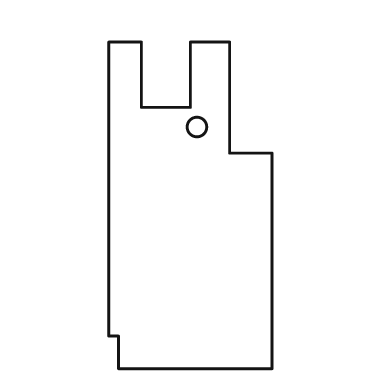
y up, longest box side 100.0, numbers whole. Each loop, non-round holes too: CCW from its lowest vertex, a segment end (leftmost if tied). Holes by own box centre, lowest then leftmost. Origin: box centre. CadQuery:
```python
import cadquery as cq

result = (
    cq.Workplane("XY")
    .moveTo(-22.0, -50.0)
    .lineTo(25.0, -50.0)
    .lineTo(25.0, 16.0)
    .lineTo(12.0, 16.0)
    .lineTo(12.0, 50.0)
    .lineTo(0.0, 50.0)
    .lineTo(0.0, 30.0)
    .lineTo(-15.0, 30.0)
    .lineTo(-15.0, 50.0)
    .lineTo(-25.0, 50.0)
    .lineTo(-25.0, -40.0)
    .lineTo(-22.0, -40.0)
    .close()
    .moveTo(2.0, 24.0)
    .circle(3.0)
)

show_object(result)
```